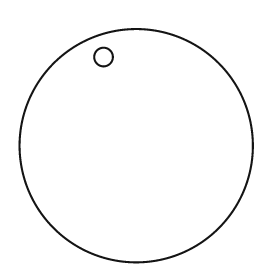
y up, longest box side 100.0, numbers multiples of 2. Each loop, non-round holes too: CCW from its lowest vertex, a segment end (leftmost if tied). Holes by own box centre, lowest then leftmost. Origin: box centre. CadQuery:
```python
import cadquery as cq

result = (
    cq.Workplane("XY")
    .moveTo(0.0, 0.0)
    .circle(50.0)
    .moveTo(-14.0, 38.0)
    .circle(4.0)
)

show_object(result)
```